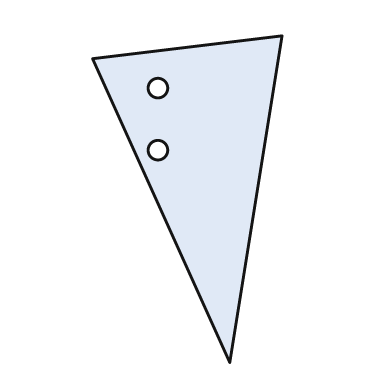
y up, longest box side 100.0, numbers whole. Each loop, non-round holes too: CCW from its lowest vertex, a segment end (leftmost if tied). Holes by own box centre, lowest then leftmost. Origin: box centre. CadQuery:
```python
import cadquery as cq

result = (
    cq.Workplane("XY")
    .moveTo(13.0, -50.0)
    .lineTo(29.0, 50.0)
    .lineTo(-29.0, 43.0)
    .close()
    .moveTo(-9.0, 15.0)
    .circle(3.0)
    .moveTo(-9.0, 34.0)
    .circle(3.0)
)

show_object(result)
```